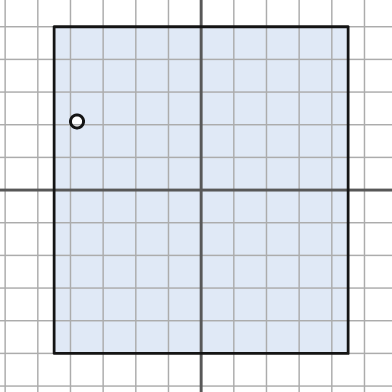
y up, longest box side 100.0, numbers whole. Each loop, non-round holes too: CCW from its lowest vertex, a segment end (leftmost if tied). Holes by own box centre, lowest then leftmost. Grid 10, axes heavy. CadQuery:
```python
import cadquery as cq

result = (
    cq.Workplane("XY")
    .moveTo(-45.0, -50.0)
    .lineTo(45.0, -50.0)
    .lineTo(45.0, 50.0)
    .lineTo(-45.0, 50.0)
    .close()
    .moveTo(-38.0, 21.0)
    .circle(2.0)
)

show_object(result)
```